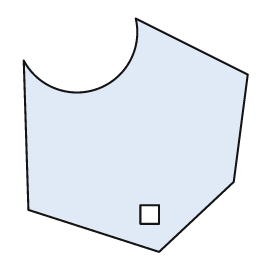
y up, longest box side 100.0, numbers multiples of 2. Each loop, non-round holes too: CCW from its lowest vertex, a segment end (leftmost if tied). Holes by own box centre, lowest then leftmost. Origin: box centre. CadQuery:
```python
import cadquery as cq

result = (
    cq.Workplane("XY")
    .moveTo(10.0, -50.0)
    .lineTo(42.0, -20.0)
    .lineTo(48.0, 26.0)
    .lineTo(0.0, 50.0)
    .threePointArc((-16.0, 20.0), (-48.0, 32.0))
    .lineTo(-46.0, -32.0)
    .close()
    .moveTo(2.0, -38.0)
    .lineTo(10.0, -38.0)
    .lineTo(10.0, -30.0)
    .lineTo(2.0, -30.0)
    .close()
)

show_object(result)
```